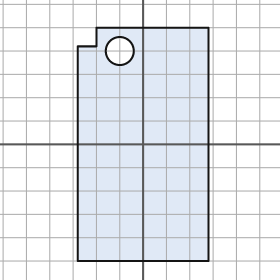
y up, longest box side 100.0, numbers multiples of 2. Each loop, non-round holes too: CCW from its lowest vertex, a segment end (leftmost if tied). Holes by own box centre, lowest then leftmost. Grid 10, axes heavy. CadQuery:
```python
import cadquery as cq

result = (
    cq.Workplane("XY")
    .moveTo(-28.0, -50.0)
    .lineTo(28.0, -50.0)
    .lineTo(28.0, 50.0)
    .lineTo(-20.0, 50.0)
    .lineTo(-20.0, 42.0)
    .lineTo(-28.0, 42.0)
    .close()
    .moveTo(-10.0, 40.0)
    .circle(6.0)
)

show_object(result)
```